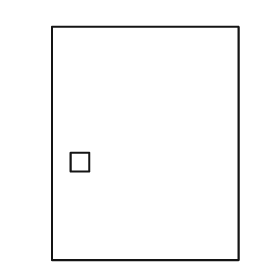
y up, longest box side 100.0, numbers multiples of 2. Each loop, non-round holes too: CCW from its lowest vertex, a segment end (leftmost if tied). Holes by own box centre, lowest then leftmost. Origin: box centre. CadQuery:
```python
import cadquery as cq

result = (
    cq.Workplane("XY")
    .moveTo(-40.0, -50.0)
    .lineTo(40.0, -50.0)
    .lineTo(40.0, 50.0)
    .lineTo(-40.0, 50.0)
    .close()
    .moveTo(-32.0, -12.0)
    .lineTo(-24.0, -12.0)
    .lineTo(-24.0, -4.0)
    .lineTo(-32.0, -4.0)
    .close()
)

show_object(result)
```